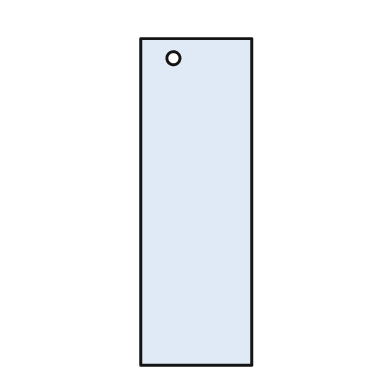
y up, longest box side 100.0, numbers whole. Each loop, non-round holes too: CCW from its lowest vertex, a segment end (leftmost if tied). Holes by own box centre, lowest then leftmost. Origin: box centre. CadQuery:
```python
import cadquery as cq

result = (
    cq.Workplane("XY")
    .moveTo(-17.0, -50.0)
    .lineTo(17.0, -50.0)
    .lineTo(17.0, 50.0)
    .lineTo(-17.0, 50.0)
    .close()
    .moveTo(-7.0, 44.0)
    .circle(2.0)
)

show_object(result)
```